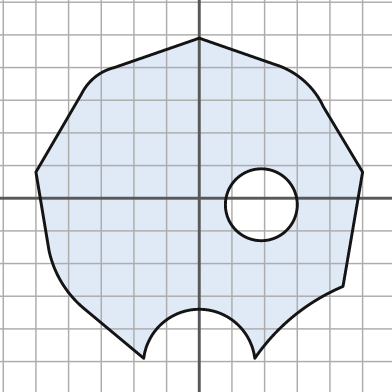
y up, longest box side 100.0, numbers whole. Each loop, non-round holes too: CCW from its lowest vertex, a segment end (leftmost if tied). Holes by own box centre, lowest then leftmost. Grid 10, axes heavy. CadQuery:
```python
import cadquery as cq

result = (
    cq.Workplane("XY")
    .moveTo(-17.0, -49.0)
    .threePointArc((0.0, -34.0), (17.0, -49.0))
    .threePointArc((29.0, -36.0), (44.0, -27.0))
    .lineTo(50.0, 8.0)
    .lineTo(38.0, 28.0)
    .threePointArc((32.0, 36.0), (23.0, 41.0))
    .lineTo(0.0, 49.0)
    .lineTo(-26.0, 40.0)
    .threePointArc((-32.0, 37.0), (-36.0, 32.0))
    .lineTo(-50.0, 8.0)
    .lineTo(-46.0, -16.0)
    .threePointArc((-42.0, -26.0), (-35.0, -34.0))
    .close()
    .moveTo(19.0, -2.0)
    .circle(11.0)
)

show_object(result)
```